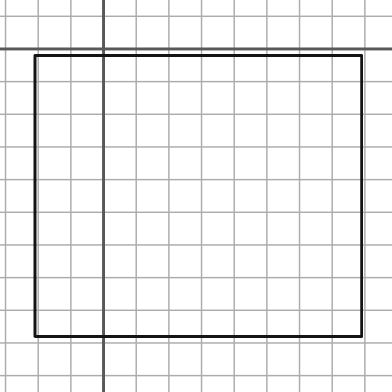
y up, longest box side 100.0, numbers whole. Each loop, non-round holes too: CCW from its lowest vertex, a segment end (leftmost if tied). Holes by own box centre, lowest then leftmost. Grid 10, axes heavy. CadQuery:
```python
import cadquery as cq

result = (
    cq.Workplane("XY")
    .moveTo(-21.0, -88.0)
    .lineTo(79.0, -88.0)
    .lineTo(79.0, -2.0)
    .lineTo(-21.0, -2.0)
    .close()
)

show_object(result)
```